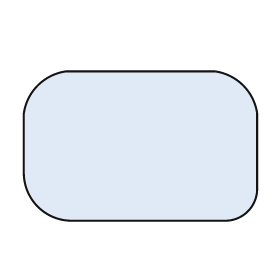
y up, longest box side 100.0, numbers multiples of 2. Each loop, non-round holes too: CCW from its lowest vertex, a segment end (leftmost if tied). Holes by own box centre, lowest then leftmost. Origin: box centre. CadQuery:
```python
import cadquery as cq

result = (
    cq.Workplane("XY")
    .moveTo(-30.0, -32.0)
    .lineTo(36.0, -32.0)
    .threePointArc((46.0, -28.0), (50.0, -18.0))
    .lineTo(50.0, 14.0)
    .threePointArc((44.0, 26.0), (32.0, 32.0))
    .lineTo(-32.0, 32.0)
    .threePointArc((-44.0, 26.0), (-50.0, 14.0))
    .lineTo(-50.0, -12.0)
    .threePointArc((-44.0, -26.0), (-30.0, -32.0))
    .close()
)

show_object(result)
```